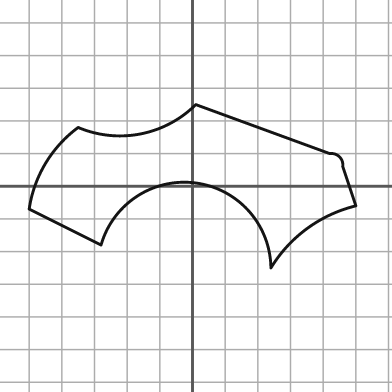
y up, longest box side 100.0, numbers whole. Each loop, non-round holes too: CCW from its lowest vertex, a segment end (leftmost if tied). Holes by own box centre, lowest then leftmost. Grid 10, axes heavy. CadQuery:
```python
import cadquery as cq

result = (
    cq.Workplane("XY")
    .moveTo(24.0, -25.0)
    .threePointArc((35.0, -13.0), (50.0, -6.0))
    .lineTo(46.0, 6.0)
    .threePointArc((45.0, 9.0), (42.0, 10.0))
    .lineTo(1.0, 25.0)
    .threePointArc((-16.0, 16.0), (-35.0, 18.0))
    .threePointArc((-45.0, 7.0), (-50.0, -7.0))
    .lineTo(-28.0, -18.0)
    .threePointArc((1.0, 1.0), (24.0, -25.0))
    .close()
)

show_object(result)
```